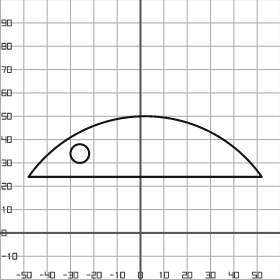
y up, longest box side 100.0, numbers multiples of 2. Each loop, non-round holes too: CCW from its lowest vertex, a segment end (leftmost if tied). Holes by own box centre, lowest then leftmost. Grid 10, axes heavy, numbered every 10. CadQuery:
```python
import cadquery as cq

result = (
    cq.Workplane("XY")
    .moveTo(-48.0, 24.0)
    .lineTo(52.0, 24.0)
    .threePointArc((2.0, 50.0), (-48.0, 24.0))
    .close()
    .moveTo(-26.0, 34.0)
    .circle(4.0)
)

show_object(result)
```